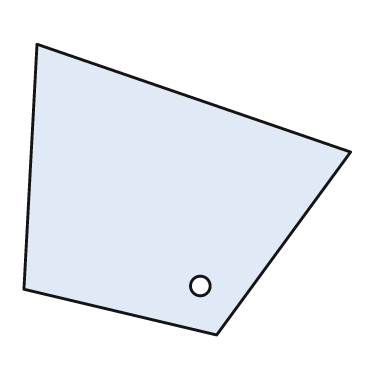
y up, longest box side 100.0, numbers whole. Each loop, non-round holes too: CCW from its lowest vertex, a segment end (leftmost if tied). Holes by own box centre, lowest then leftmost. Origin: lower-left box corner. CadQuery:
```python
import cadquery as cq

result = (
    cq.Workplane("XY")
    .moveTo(59.0, 0.0)
    .lineTo(100.0, 56.0)
    .lineTo(4.0, 89.0)
    .lineTo(0.0, 14.0)
    .close()
    .moveTo(54.0, 15.0)
    .circle(3.0)
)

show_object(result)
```